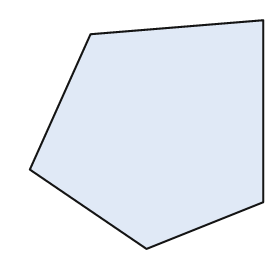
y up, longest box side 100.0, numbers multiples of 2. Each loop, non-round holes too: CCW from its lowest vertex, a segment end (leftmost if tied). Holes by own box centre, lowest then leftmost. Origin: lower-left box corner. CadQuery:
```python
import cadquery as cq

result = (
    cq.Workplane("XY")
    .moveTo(50.0, 0.0)
    .lineTo(100.0, 20.0)
    .lineTo(100.0, 98.0)
    .lineTo(26.0, 92.0)
    .lineTo(0.0, 34.0)
    .close()
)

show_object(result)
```